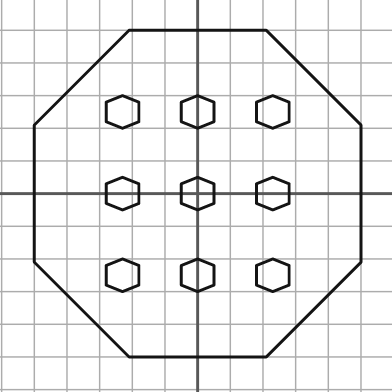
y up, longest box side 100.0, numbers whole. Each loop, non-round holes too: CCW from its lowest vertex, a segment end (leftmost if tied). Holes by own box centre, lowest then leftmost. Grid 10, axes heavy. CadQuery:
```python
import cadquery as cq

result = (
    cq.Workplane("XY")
    .moveTo(-21.0, -50.0)
    .lineTo(21.0, -50.0)
    .lineTo(50.0, -21.0)
    .lineTo(50.0, 21.0)
    .lineTo(21.0, 50.0)
    .lineTo(-21.0, 50.0)
    .lineTo(-50.0, 21.0)
    .lineTo(-50.0, -21.0)
    .close()
    .moveTo(-23.0, -30.0)
    .lineTo(-18.0, -28.0)
    .lineTo(-18.0, -22.0)
    .lineTo(-23.0, -20.0)
    .lineTo(-28.0, -22.0)
    .lineTo(-28.0, -28.0)
    .close()
    .moveTo(0.0, -30.0)
    .lineTo(5.0, -28.0)
    .lineTo(5.0, -22.0)
    .lineTo(0.0, -20.0)
    .lineTo(-5.0, -22.0)
    .lineTo(-5.0, -28.0)
    .close()
    .moveTo(23.0, -30.0)
    .lineTo(28.0, -28.0)
    .lineTo(28.0, -22.0)
    .lineTo(23.0, -20.0)
    .lineTo(18.0, -22.0)
    .lineTo(18.0, -28.0)
    .close()
    .moveTo(-23.0, -5.0)
    .lineTo(-18.0, -3.0)
    .lineTo(-18.0, 3.0)
    .lineTo(-23.0, 5.0)
    .lineTo(-28.0, 3.0)
    .lineTo(-28.0, -3.0)
    .close()
    .moveTo(0.0, -5.0)
    .lineTo(5.0, -3.0)
    .lineTo(5.0, 3.0)
    .lineTo(0.0, 5.0)
    .lineTo(-5.0, 3.0)
    .lineTo(-5.0, -3.0)
    .close()
    .moveTo(23.0, -5.0)
    .lineTo(28.0, -3.0)
    .lineTo(28.0, 3.0)
    .lineTo(23.0, 5.0)
    .lineTo(18.0, 3.0)
    .lineTo(18.0, -3.0)
    .close()
    .moveTo(-23.0, 20.0)
    .lineTo(-18.0, 22.0)
    .lineTo(-18.0, 28.0)
    .lineTo(-23.0, 30.0)
    .lineTo(-28.0, 28.0)
    .lineTo(-28.0, 22.0)
    .close()
    .moveTo(0.0, 20.0)
    .lineTo(5.0, 22.0)
    .lineTo(5.0, 28.0)
    .lineTo(0.0, 30.0)
    .lineTo(-5.0, 28.0)
    .lineTo(-5.0, 22.0)
    .close()
    .moveTo(23.0, 20.0)
    .lineTo(28.0, 22.0)
    .lineTo(28.0, 28.0)
    .lineTo(23.0, 30.0)
    .lineTo(18.0, 28.0)
    .lineTo(18.0, 22.0)
    .close()
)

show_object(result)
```